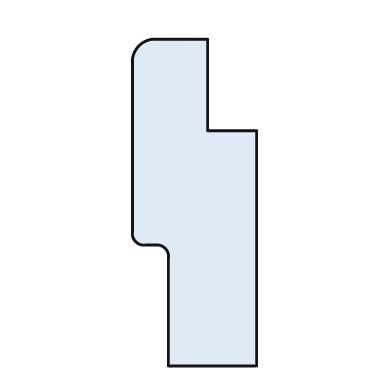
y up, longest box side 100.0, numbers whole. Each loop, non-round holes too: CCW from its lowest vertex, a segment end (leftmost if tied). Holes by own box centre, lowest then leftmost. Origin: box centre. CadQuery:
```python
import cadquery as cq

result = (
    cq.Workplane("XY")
    .moveTo(-8.0, -50.0)
    .lineTo(19.0, -50.0)
    .lineTo(19.0, 22.0)
    .lineTo(4.0, 22.0)
    .lineTo(4.0, 50.0)
    .lineTo(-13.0, 50.0)
    .threePointArc((-17.0, 48.0), (-19.0, 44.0))
    .lineTo(-19.0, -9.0)
    .threePointArc((-18.0, -12.0), (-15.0, -13.0))
    .lineTo(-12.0, -13.0)
    .threePointArc((-9.0, -14.0), (-8.0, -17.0))
    .close()
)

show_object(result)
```